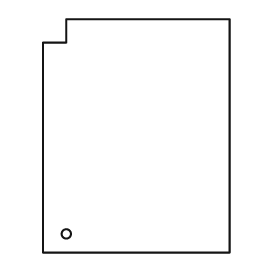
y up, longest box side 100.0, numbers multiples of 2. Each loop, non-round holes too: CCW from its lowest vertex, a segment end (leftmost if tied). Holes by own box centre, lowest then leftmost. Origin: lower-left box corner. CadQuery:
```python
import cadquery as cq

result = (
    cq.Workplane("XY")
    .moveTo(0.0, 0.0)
    .lineTo(80.0, 0.0)
    .lineTo(80.0, 100.0)
    .lineTo(10.0, 100.0)
    .lineTo(10.0, 90.0)
    .lineTo(0.0, 90.0)
    .close()
    .moveTo(10.0, 8.0)
    .circle(2.0)
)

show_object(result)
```